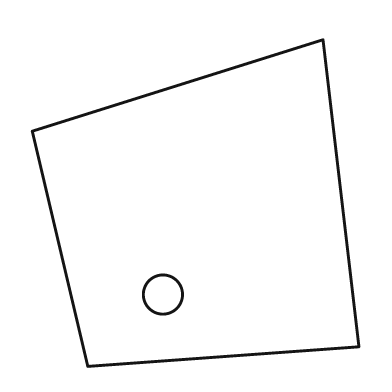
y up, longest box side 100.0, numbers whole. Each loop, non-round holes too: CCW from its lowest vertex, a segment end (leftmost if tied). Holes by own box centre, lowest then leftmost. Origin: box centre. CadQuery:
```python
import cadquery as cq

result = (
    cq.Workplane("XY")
    .moveTo(-33.0, -50.0)
    .lineTo(50.0, -44.0)
    .lineTo(39.0, 50.0)
    .lineTo(-50.0, 22.0)
    .close()
    .moveTo(-10.0, -28.0)
    .circle(6.0)
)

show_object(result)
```